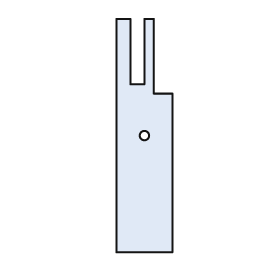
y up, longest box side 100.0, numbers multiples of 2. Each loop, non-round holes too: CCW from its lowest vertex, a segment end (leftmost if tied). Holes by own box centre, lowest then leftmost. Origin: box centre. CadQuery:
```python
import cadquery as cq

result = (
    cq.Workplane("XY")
    .moveTo(-12.0, -50.0)
    .lineTo(12.0, -50.0)
    .lineTo(12.0, 18.0)
    .lineTo(4.0, 18.0)
    .lineTo(4.0, 50.0)
    .lineTo(0.0, 50.0)
    .lineTo(0.0, 22.0)
    .lineTo(-6.0, 22.0)
    .lineTo(-6.0, 50.0)
    .lineTo(-12.0, 50.0)
    .close()
    .moveTo(0.0, 0.0)
    .circle(2.0)
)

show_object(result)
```